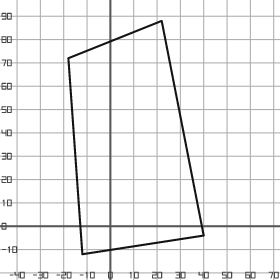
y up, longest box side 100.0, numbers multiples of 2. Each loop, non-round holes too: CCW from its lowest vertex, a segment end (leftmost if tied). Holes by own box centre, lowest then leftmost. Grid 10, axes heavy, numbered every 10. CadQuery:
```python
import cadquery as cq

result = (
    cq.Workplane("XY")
    .moveTo(-12.0, -12.0)
    .lineTo(40.0, -4.0)
    .lineTo(22.0, 88.0)
    .lineTo(-18.0, 72.0)
    .close()
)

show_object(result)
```